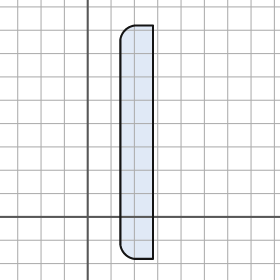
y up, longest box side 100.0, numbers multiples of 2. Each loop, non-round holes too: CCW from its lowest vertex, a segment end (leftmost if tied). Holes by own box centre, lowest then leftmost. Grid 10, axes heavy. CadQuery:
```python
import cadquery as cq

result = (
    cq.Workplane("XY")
    .moveTo(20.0, -18.0)
    .lineTo(28.0, -18.0)
    .lineTo(28.0, 82.0)
    .lineTo(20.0, 82.0)
    .threePointArc((16.0, 80.0), (14.0, 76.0))
    .lineTo(14.0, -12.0)
    .threePointArc((16.0, -16.0), (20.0, -18.0))
    .close()
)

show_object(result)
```